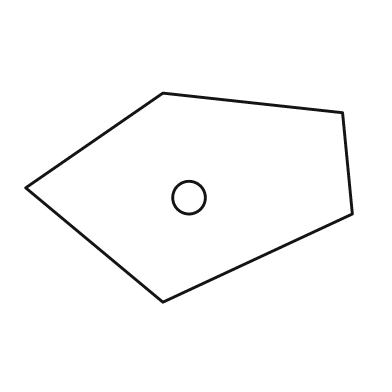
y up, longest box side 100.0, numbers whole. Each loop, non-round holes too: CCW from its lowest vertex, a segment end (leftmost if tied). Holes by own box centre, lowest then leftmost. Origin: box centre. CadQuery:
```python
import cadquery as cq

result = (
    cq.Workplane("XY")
    .moveTo(-8.0, -32.0)
    .lineTo(50.0, -5.0)
    .lineTo(47.0, 26.0)
    .lineTo(-8.0, 32.0)
    .lineTo(-50.0, 3.0)
    .close()
    .moveTo(0.0, 0.0)
    .circle(5.0)
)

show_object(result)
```